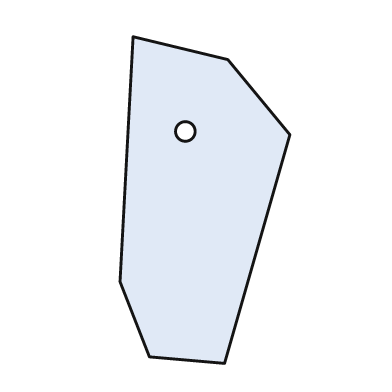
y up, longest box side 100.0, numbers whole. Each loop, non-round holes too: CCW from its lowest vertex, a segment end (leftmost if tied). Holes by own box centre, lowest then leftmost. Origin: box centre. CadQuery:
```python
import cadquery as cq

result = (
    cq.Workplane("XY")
    .moveTo(6.0, -50.0)
    .lineTo(26.0, 20.0)
    .lineTo(7.0, 43.0)
    .lineTo(-22.0, 50.0)
    .lineTo(-26.0, -25.0)
    .lineTo(-17.0, -48.0)
    .close()
    .moveTo(-6.0, 21.0)
    .circle(3.0)
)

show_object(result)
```